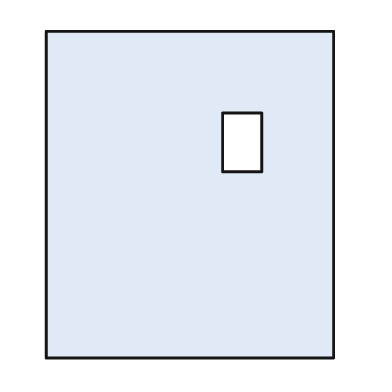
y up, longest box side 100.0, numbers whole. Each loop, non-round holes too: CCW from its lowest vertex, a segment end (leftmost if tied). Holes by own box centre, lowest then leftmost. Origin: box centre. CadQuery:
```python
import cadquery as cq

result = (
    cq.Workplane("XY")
    .moveTo(-44.0, -50.0)
    .lineTo(44.0, -50.0)
    .lineTo(44.0, 50.0)
    .lineTo(-44.0, 50.0)
    .close()
    .moveTo(10.0, 7.0)
    .lineTo(22.0, 7.0)
    .lineTo(22.0, 25.0)
    .lineTo(10.0, 25.0)
    .close()
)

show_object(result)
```